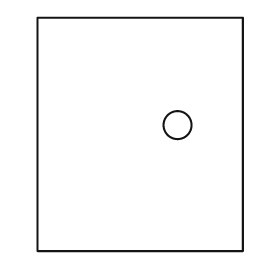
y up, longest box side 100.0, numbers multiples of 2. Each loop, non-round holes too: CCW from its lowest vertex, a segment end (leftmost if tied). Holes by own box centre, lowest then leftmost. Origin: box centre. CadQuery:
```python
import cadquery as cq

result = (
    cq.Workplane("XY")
    .moveTo(-44.0, -50.0)
    .lineTo(44.0, -50.0)
    .lineTo(44.0, 50.0)
    .lineTo(-44.0, 50.0)
    .close()
    .moveTo(16.0, 4.0)
    .circle(6.0)
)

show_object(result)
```